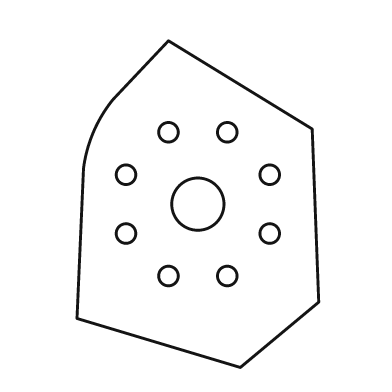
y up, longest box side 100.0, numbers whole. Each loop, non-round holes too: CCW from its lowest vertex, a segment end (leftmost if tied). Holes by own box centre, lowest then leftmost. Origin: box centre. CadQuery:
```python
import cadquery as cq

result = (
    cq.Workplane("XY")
    .moveTo(13.0, -50.0)
    .lineTo(37.0, -30.0)
    .lineTo(35.0, 23.0)
    .lineTo(-9.0, 50.0)
    .lineTo(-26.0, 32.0)
    .threePointArc((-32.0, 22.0), (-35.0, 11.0))
    .lineTo(-37.0, -35.0)
    .close()
    .moveTo(-9.0, -22.0)
    .circle(3.0)
    .moveTo(9.0, -22.0)
    .circle(3.0)
    .moveTo(-22.0, -9.0)
    .circle(3.0)
    .moveTo(22.0, -9.0)
    .circle(3.0)
    .moveTo(0.0, 0.0)
    .circle(8.0)
    .moveTo(-22.0, 9.0)
    .circle(3.0)
    .moveTo(22.0, 9.0)
    .circle(3.0)
    .moveTo(-9.0, 22.0)
    .circle(3.0)
    .moveTo(9.0, 22.0)
    .circle(3.0)
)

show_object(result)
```